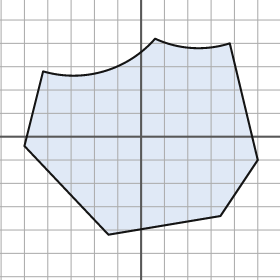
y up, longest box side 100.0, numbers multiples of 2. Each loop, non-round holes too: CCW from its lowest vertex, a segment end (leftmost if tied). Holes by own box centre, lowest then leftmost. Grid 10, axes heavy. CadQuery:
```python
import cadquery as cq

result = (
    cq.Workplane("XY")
    .moveTo(-14.0, -42.0)
    .lineTo(34.0, -34.0)
    .lineTo(50.0, -10.0)
    .lineTo(38.0, 40.0)
    .threePointArc((22.0, 38.0), (6.0, 42.0))
    .threePointArc((-16.0, 28.0), (-42.0, 28.0))
    .lineTo(-50.0, -4.0)
    .close()
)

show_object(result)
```